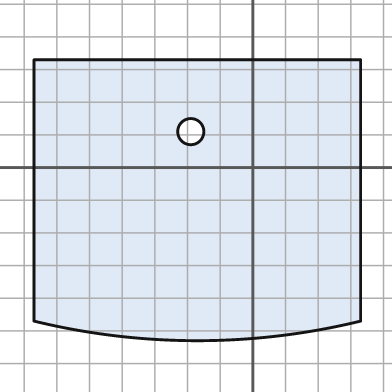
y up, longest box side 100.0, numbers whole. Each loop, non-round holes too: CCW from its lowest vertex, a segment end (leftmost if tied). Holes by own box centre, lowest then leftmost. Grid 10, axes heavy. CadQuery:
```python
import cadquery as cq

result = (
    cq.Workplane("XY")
    .moveTo(-67.0, -47.0)
    .threePointArc((-17.0, -53.0), (33.0, -47.0))
    .lineTo(33.0, 33.0)
    .lineTo(-67.0, 33.0)
    .close()
    .moveTo(-19.0, 11.0)
    .circle(4.0)
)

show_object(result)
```